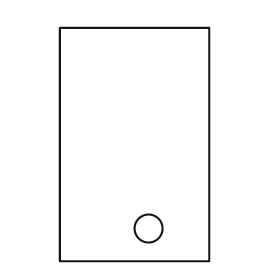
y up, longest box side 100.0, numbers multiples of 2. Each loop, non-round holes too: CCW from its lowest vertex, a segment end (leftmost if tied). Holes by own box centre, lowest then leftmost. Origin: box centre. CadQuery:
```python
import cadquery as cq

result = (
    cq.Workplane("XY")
    .moveTo(-32.0, -50.0)
    .lineTo(32.0, -50.0)
    .lineTo(32.0, 50.0)
    .lineTo(-32.0, 50.0)
    .close()
    .moveTo(6.0, -36.0)
    .circle(6.0)
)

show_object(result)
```